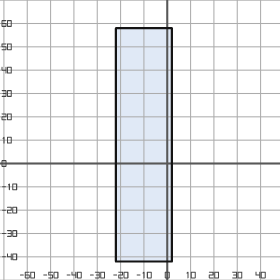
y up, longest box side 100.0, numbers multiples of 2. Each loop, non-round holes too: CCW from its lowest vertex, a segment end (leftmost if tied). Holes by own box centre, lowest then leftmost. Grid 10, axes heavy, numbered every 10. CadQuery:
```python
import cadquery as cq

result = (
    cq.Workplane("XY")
    .moveTo(-22.0, -42.0)
    .lineTo(2.0, -42.0)
    .lineTo(2.0, 58.0)
    .lineTo(-22.0, 58.0)
    .close()
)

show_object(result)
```